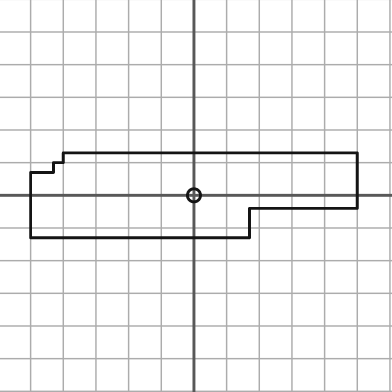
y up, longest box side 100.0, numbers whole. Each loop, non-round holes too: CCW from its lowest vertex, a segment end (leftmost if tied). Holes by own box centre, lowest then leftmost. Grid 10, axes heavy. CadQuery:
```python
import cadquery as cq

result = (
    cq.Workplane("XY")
    .moveTo(-50.0, -13.0)
    .lineTo(17.0, -13.0)
    .lineTo(17.0, -4.0)
    .lineTo(50.0, -4.0)
    .lineTo(50.0, 13.0)
    .lineTo(-40.0, 13.0)
    .lineTo(-40.0, 10.0)
    .lineTo(-43.0, 10.0)
    .lineTo(-43.0, 7.0)
    .lineTo(-50.0, 7.0)
    .close()
    .moveTo(0.0, 0.0)
    .circle(2.0)
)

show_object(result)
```